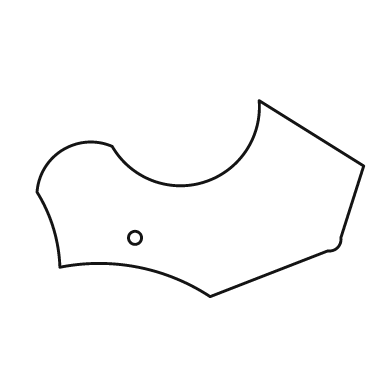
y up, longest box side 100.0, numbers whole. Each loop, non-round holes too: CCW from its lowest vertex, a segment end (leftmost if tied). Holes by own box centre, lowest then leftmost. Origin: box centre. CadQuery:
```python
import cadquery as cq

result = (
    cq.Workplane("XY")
    .moveTo(3.0, -30.0)
    .lineTo(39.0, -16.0)
    .threePointArc((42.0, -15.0), (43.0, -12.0))
    .lineTo(50.0, 10.0)
    .lineTo(18.0, 30.0)
    .threePointArc((1.0, 5.0), (-27.0, 16.0))
    .threePointArc((-42.0, 15.0), (-50.0, 2.0))
    .threePointArc((-45.0, -9.0), (-43.0, -21.0))
    .threePointArc((-19.0, -21.0), (3.0, -30.0))
    .close()
    .moveTo(-20.0, -12.0)
    .circle(2.0)
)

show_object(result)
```